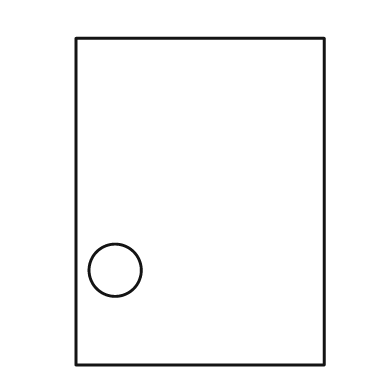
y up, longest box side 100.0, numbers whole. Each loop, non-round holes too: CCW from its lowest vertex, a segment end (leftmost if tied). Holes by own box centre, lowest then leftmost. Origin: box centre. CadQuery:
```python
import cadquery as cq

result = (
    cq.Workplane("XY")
    .moveTo(-38.0, -50.0)
    .lineTo(38.0, -50.0)
    .lineTo(38.0, 50.0)
    .lineTo(-38.0, 50.0)
    .close()
    .moveTo(-26.0, -21.0)
    .circle(8.0)
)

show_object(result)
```